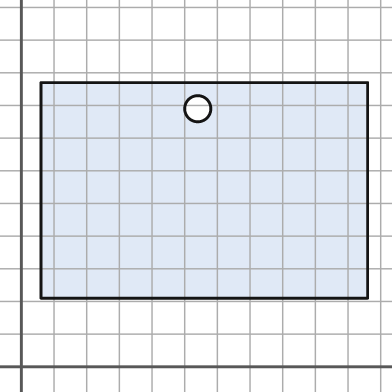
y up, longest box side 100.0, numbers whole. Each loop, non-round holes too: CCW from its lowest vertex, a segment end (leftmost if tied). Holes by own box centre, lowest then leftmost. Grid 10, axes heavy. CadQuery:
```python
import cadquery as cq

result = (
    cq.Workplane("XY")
    .moveTo(6.0, 21.0)
    .lineTo(106.0, 21.0)
    .lineTo(106.0, 87.0)
    .lineTo(6.0, 87.0)
    .close()
    .moveTo(54.0, 79.0)
    .circle(4.0)
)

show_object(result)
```